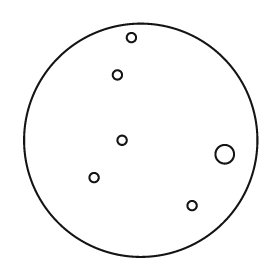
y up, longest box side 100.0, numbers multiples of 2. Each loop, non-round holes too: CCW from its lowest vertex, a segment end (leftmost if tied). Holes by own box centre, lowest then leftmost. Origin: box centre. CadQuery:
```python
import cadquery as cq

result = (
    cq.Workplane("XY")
    .moveTo(0.0, 0.0)
    .circle(50.0)
    .moveTo(22.0, -28.0)
    .circle(2.0)
    .moveTo(-20.0, -16.0)
    .circle(2.0)
    .moveTo(36.0, -6.0)
    .circle(4.0)
    .moveTo(-8.0, 0.0)
    .circle(2.0)
    .moveTo(-10.0, 28.0)
    .circle(2.0)
    .moveTo(-4.0, 44.0)
    .circle(2.0)
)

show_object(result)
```